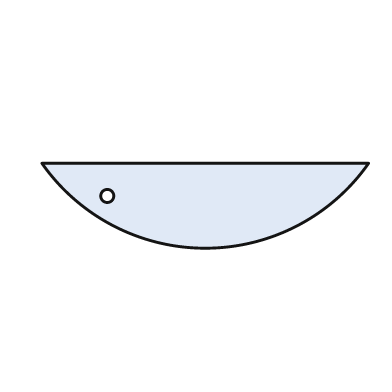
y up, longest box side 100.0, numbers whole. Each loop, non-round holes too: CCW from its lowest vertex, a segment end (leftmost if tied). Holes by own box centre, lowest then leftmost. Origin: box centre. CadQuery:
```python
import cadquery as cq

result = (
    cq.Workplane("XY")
    .moveTo(-50.0, 13.0)
    .threePointArc((0.0, -13.0), (50.0, 13.0))
    .close()
    .moveTo(-30.0, 3.0)
    .circle(2.0)
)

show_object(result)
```